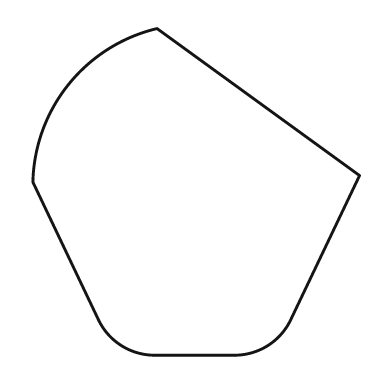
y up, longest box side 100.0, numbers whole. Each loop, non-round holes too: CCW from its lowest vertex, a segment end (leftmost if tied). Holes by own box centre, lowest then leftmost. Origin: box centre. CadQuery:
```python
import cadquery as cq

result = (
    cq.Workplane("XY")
    .moveTo(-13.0, -50.0)
    .lineTo(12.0, -50.0)
    .threePointArc((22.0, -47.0), (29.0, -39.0))
    .lineTo(50.0, 5.0)
    .lineTo(-12.0, 50.0)
    .threePointArc((-39.0, 33.0), (-50.0, 3.0))
    .lineTo(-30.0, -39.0)
    .threePointArc((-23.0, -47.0), (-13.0, -50.0))
    .close()
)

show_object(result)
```